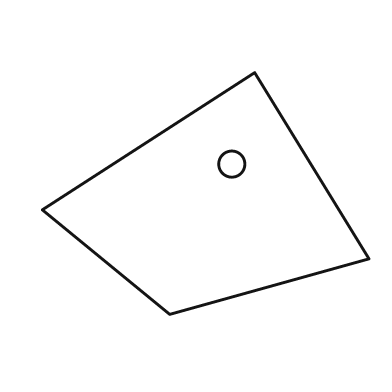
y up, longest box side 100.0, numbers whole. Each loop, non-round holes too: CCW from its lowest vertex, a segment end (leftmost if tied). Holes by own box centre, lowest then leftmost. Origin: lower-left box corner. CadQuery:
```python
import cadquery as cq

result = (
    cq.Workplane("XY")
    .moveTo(39.0, 0.0)
    .lineTo(100.0, 17.0)
    .lineTo(65.0, 74.0)
    .lineTo(0.0, 32.0)
    .close()
    .moveTo(58.0, 46.0)
    .circle(4.0)
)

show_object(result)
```